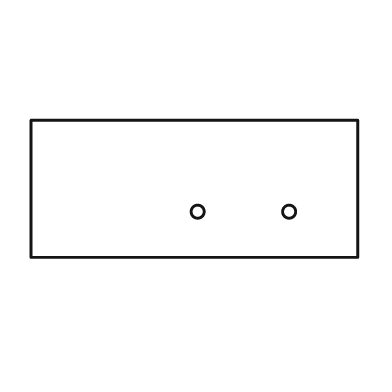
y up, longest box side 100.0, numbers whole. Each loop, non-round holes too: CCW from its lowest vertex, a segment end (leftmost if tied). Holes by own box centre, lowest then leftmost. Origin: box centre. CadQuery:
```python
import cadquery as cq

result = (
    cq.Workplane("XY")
    .moveTo(-50.0, -21.0)
    .lineTo(50.0, -21.0)
    .lineTo(50.0, 21.0)
    .lineTo(-50.0, 21.0)
    .close()
    .moveTo(1.0, -7.0)
    .circle(2.0)
    .moveTo(29.0, -7.0)
    .circle(2.0)
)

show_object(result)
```